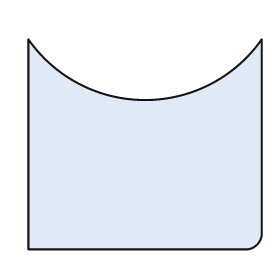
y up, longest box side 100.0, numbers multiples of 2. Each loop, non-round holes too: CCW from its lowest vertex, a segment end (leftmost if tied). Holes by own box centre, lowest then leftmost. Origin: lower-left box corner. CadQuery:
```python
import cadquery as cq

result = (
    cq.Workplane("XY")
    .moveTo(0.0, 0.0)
    .lineTo(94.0, 0.0)
    .threePointArc((98.0, 2.0), (100.0, 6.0))
    .lineTo(100.0, 90.0)
    .threePointArc((50.0, 64.0), (0.0, 90.0))
    .close()
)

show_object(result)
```